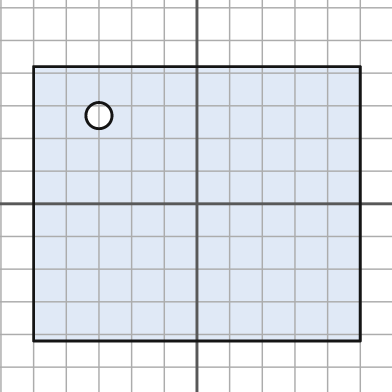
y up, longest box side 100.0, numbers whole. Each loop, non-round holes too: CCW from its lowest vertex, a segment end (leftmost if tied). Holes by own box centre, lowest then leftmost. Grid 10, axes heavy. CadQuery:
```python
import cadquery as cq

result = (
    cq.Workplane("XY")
    .moveTo(-50.0, -42.0)
    .lineTo(50.0, -42.0)
    .lineTo(50.0, 42.0)
    .lineTo(-50.0, 42.0)
    .close()
    .moveTo(-30.0, 27.0)
    .circle(4.0)
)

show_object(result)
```